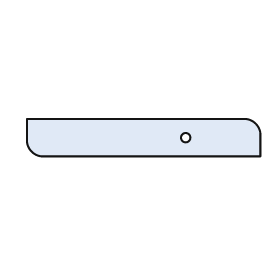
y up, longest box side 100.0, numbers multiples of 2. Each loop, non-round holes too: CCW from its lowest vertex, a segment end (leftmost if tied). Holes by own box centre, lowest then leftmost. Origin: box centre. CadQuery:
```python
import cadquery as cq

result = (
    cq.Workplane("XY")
    .moveTo(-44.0, -8.0)
    .lineTo(50.0, -8.0)
    .lineTo(50.0, 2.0)
    .threePointArc((48.0, 6.0), (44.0, 8.0))
    .lineTo(-50.0, 8.0)
    .lineTo(-50.0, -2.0)
    .threePointArc((-48.0, -6.0), (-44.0, -8.0))
    .close()
    .moveTo(18.0, 0.0)
    .circle(2.0)
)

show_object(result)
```